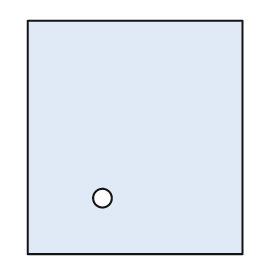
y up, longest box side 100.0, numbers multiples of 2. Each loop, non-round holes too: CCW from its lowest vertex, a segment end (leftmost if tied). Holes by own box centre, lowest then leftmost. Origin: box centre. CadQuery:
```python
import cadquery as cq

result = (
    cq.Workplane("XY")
    .moveTo(-46.0, -50.0)
    .lineTo(46.0, -50.0)
    .lineTo(46.0, 50.0)
    .lineTo(-46.0, 50.0)
    .close()
    .moveTo(-14.0, -26.0)
    .circle(4.0)
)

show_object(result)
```